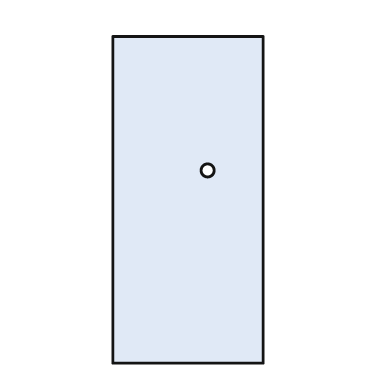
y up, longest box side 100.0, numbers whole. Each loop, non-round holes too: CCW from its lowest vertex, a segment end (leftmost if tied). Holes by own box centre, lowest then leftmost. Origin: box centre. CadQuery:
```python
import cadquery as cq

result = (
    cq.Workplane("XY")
    .moveTo(-23.0, -50.0)
    .lineTo(23.0, -50.0)
    .lineTo(23.0, 50.0)
    .lineTo(-23.0, 50.0)
    .close()
    .moveTo(6.0, 9.0)
    .circle(2.0)
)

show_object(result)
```